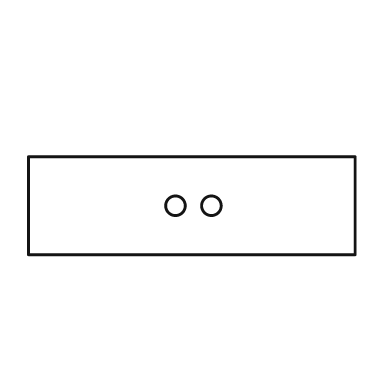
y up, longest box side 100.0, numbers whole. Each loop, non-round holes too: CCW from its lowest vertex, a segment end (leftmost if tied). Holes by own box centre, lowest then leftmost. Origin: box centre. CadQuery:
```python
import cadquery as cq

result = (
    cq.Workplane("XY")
    .moveTo(-50.0, -15.0)
    .lineTo(50.0, -15.0)
    .lineTo(50.0, 15.0)
    .lineTo(-50.0, 15.0)
    .close()
    .moveTo(-5.0, 0.0)
    .circle(3.0)
    .moveTo(6.0, 0.0)
    .circle(3.0)
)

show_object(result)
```